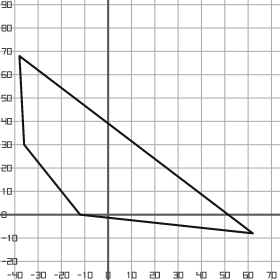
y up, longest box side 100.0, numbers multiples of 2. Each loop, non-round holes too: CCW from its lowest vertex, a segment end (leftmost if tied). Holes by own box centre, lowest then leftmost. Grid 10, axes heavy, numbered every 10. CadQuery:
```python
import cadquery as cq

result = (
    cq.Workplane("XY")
    .moveTo(62.0, -8.0)
    .lineTo(-38.0, 68.0)
    .lineTo(-36.0, 30.0)
    .lineTo(-12.0, 0.0)
    .close()
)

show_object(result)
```